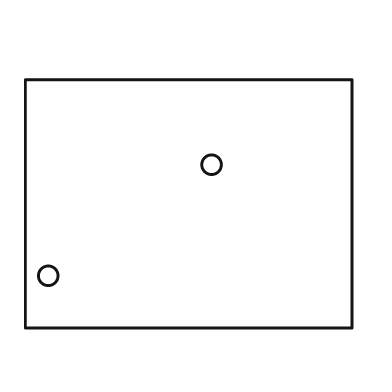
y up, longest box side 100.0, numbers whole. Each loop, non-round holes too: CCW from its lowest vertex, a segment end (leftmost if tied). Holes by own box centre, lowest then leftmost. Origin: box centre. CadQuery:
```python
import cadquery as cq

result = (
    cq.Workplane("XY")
    .moveTo(-50.0, -38.0)
    .lineTo(50.0, -38.0)
    .lineTo(50.0, 38.0)
    .lineTo(-50.0, 38.0)
    .close()
    .moveTo(-43.0, -22.0)
    .circle(3.0)
    .moveTo(7.0, 12.0)
    .circle(3.0)
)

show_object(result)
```